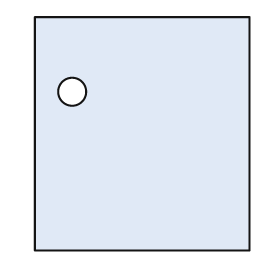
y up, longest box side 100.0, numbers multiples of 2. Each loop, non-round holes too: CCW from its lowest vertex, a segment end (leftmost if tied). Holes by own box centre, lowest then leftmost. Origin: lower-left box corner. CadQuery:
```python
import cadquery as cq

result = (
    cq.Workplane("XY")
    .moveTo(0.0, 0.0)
    .lineTo(92.0, 0.0)
    .lineTo(92.0, 100.0)
    .lineTo(0.0, 100.0)
    .close()
    .moveTo(16.0, 68.0)
    .circle(6.0)
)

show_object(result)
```